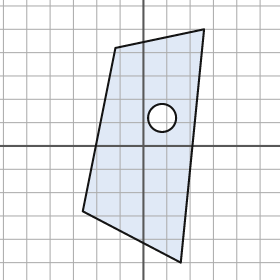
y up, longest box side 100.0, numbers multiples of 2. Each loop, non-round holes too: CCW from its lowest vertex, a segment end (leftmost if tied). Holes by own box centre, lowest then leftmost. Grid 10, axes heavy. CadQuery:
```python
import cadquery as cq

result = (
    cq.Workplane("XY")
    .moveTo(16.0, -50.0)
    .lineTo(26.0, 50.0)
    .lineTo(-12.0, 42.0)
    .lineTo(-26.0, -28.0)
    .close()
    .moveTo(8.0, 12.0)
    .circle(6.0)
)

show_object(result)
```